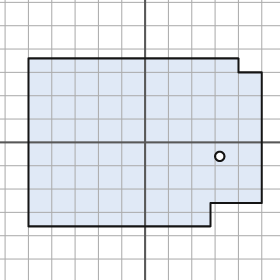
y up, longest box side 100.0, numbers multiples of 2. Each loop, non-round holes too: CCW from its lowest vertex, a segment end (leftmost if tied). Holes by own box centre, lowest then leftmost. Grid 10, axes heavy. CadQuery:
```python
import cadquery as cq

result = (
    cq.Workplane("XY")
    .moveTo(-50.0, -36.0)
    .lineTo(28.0, -36.0)
    .lineTo(28.0, -26.0)
    .lineTo(50.0, -26.0)
    .lineTo(50.0, 30.0)
    .lineTo(40.0, 30.0)
    .lineTo(40.0, 36.0)
    .lineTo(-50.0, 36.0)
    .close()
    .moveTo(32.0, -6.0)
    .circle(2.0)
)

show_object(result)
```